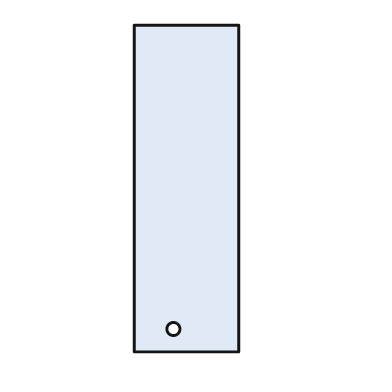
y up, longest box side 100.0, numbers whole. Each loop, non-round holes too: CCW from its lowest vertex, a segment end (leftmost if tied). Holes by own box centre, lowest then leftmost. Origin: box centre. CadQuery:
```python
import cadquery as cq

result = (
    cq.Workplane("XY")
    .moveTo(-16.0, -50.0)
    .lineTo(16.0, -50.0)
    .lineTo(16.0, 50.0)
    .lineTo(-16.0, 50.0)
    .close()
    .moveTo(-4.0, -43.0)
    .circle(2.0)
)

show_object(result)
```